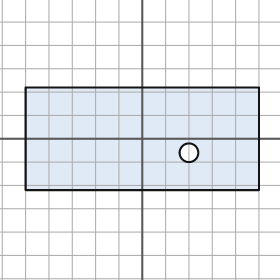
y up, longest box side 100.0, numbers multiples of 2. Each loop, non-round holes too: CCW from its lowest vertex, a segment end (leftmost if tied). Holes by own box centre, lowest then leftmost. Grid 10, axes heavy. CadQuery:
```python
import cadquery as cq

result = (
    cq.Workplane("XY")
    .moveTo(-50.0, -22.0)
    .lineTo(50.0, -22.0)
    .lineTo(50.0, 22.0)
    .lineTo(-50.0, 22.0)
    .close()
    .moveTo(20.0, -6.0)
    .circle(4.0)
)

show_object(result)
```